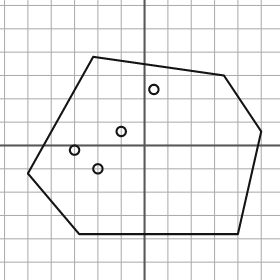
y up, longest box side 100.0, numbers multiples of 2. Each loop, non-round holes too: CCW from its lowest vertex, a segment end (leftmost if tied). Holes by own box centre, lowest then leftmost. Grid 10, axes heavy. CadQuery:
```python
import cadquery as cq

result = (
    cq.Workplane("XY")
    .moveTo(-28.0, -38.0)
    .lineTo(40.0, -38.0)
    .lineTo(50.0, 6.0)
    .lineTo(34.0, 30.0)
    .lineTo(-22.0, 38.0)
    .lineTo(-50.0, -12.0)
    .close()
    .moveTo(-20.0, -10.0)
    .circle(2.0)
    .moveTo(-30.0, -2.0)
    .circle(2.0)
    .moveTo(-10.0, 6.0)
    .circle(2.0)
    .moveTo(4.0, 24.0)
    .circle(2.0)
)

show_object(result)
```